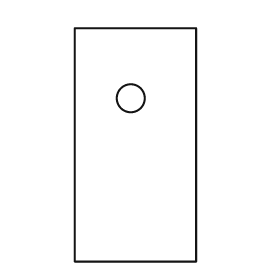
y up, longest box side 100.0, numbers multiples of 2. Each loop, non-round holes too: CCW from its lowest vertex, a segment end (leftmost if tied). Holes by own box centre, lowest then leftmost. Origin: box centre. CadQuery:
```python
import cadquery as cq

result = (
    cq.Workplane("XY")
    .moveTo(-26.0, -50.0)
    .lineTo(26.0, -50.0)
    .lineTo(26.0, 50.0)
    .lineTo(-26.0, 50.0)
    .close()
    .moveTo(-2.0, 20.0)
    .circle(6.0)
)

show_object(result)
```